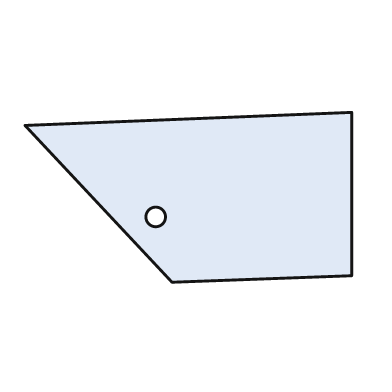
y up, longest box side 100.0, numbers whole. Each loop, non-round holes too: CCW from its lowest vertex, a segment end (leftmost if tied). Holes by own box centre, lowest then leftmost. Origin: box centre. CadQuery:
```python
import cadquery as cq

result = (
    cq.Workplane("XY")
    .moveTo(-5.0, -26.0)
    .lineTo(50.0, -24.0)
    .lineTo(50.0, 26.0)
    .lineTo(-50.0, 22.0)
    .close()
    .moveTo(-10.0, -6.0)
    .circle(3.0)
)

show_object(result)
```